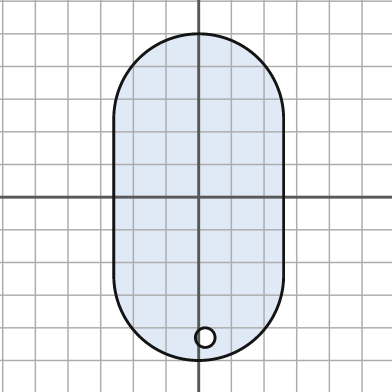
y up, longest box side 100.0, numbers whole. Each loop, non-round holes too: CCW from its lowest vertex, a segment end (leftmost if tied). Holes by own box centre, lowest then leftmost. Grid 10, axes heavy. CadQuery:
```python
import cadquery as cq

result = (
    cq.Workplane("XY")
    .moveTo(-26.0, -24.0)
    .threePointArc((0.0, -50.0), (26.0, -24.0))
    .lineTo(26.0, 24.0)
    .threePointArc((0.0, 50.0), (-26.0, 24.0))
    .close()
    .moveTo(2.0, -43.0)
    .circle(3.0)
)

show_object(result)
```